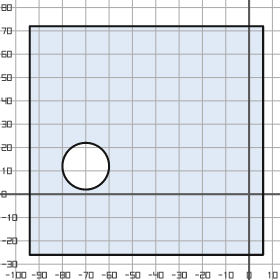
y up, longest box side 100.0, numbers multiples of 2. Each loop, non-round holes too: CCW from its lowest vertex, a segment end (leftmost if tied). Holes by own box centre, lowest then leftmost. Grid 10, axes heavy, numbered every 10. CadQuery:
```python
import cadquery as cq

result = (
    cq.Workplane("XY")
    .moveTo(-94.0, -26.0)
    .lineTo(6.0, -26.0)
    .lineTo(6.0, 72.0)
    .lineTo(-94.0, 72.0)
    .close()
    .moveTo(-70.0, 12.0)
    .circle(10.0)
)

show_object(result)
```